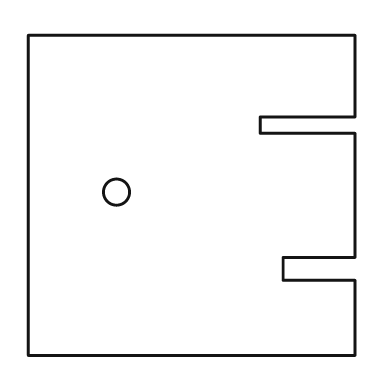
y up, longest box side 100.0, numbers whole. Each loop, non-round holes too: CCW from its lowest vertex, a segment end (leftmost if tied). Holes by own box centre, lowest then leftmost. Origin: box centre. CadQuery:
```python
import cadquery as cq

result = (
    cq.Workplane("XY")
    .moveTo(-50.0, -49.0)
    .lineTo(50.0, -49.0)
    .lineTo(50.0, -26.0)
    .lineTo(28.0, -26.0)
    .lineTo(28.0, -19.0)
    .lineTo(50.0, -19.0)
    .lineTo(50.0, 19.0)
    .lineTo(21.0, 19.0)
    .lineTo(21.0, 24.0)
    .lineTo(50.0, 24.0)
    .lineTo(50.0, 49.0)
    .lineTo(-50.0, 49.0)
    .close()
    .moveTo(-23.0, 1.0)
    .circle(4.0)
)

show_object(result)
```